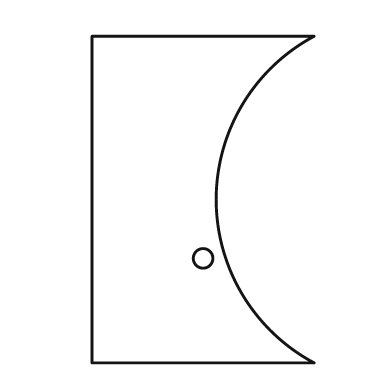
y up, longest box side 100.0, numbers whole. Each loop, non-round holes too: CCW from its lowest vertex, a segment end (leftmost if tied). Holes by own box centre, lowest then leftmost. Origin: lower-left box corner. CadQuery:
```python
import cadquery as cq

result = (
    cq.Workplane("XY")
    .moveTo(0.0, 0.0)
    .lineTo(68.0, 0.0)
    .threePointArc((38.0, 50.0), (68.0, 100.0))
    .lineTo(0.0, 100.0)
    .close()
    .moveTo(34.0, 32.0)
    .circle(3.0)
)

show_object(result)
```